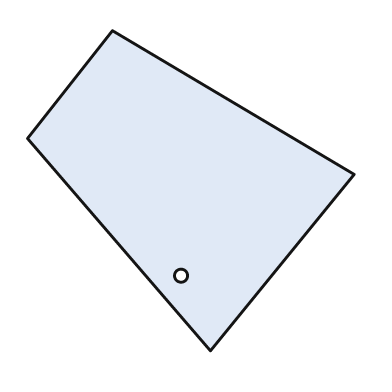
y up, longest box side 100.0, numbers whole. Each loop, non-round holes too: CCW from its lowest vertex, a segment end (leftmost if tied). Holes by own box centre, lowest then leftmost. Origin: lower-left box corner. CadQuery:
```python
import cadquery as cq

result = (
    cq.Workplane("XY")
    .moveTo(56.0, 0.0)
    .lineTo(100.0, 54.0)
    .lineTo(26.0, 98.0)
    .lineTo(0.0, 65.0)
    .close()
    .moveTo(47.0, 23.0)
    .circle(2.0)
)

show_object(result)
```